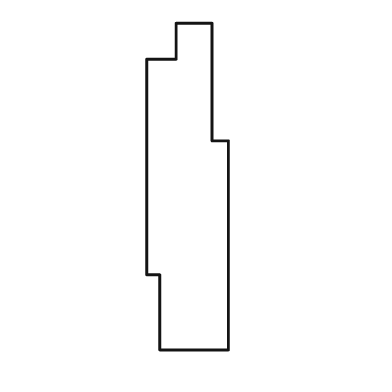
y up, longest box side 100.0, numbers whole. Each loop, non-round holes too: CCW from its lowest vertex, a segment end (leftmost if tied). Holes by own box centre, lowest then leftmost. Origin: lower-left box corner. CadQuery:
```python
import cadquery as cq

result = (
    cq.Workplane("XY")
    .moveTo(4.0, 0.0)
    .lineTo(25.0, 0.0)
    .lineTo(25.0, 64.0)
    .lineTo(20.0, 64.0)
    .lineTo(20.0, 100.0)
    .lineTo(9.0, 100.0)
    .lineTo(9.0, 89.0)
    .lineTo(0.0, 89.0)
    .lineTo(0.0, 23.0)
    .lineTo(4.0, 23.0)
    .close()
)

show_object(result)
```